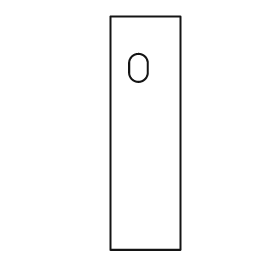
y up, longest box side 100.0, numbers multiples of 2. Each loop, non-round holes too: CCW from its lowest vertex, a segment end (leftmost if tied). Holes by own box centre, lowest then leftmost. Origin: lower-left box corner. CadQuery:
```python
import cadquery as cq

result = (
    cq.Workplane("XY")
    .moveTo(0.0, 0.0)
    .lineTo(30.0, 0.0)
    .lineTo(30.0, 100.0)
    .lineTo(0.0, 100.0)
    .close()
    .moveTo(8.0, 76.0)
    .threePointArc((12.0, 72.0), (16.0, 76.0))
    .lineTo(16.0, 80.0)
    .threePointArc((12.0, 84.0), (8.0, 80.0))
    .close()
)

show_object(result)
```